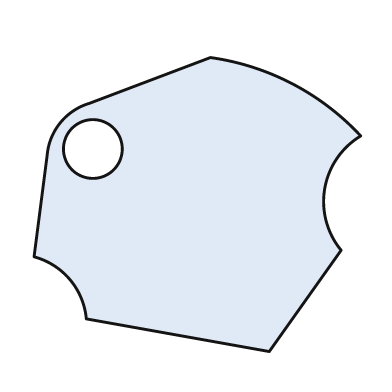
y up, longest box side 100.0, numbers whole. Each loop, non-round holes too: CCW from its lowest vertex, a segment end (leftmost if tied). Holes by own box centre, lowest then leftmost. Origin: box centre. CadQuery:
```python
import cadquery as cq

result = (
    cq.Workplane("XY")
    .moveTo(22.0, -45.0)
    .lineTo(44.0, -14.0)
    .threePointArc((39.0, 5.0), (50.0, 21.0))
    .threePointArc((29.0, 37.0), (4.0, 45.0))
    .lineTo(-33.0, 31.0)
    .threePointArc((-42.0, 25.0), (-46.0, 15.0))
    .lineTo(-50.0, -16.0)
    .threePointArc((-39.0, -23.0), (-34.0, -35.0))
    .close()
    .moveTo(-32.0, 17.0)
    .circle(9.0)
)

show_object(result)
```